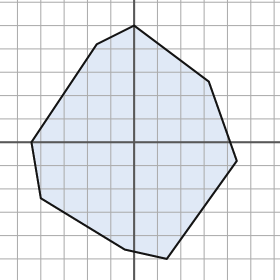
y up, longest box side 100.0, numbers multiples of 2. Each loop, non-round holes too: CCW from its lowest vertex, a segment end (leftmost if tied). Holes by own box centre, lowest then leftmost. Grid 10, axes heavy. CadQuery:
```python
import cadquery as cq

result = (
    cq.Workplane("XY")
    .moveTo(14.0, -50.0)
    .lineTo(44.0, -8.0)
    .lineTo(32.0, 26.0)
    .lineTo(0.0, 50.0)
    .lineTo(-16.0, 42.0)
    .lineTo(-44.0, 0.0)
    .lineTo(-40.0, -24.0)
    .lineTo(-4.0, -46.0)
    .close()
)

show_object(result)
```